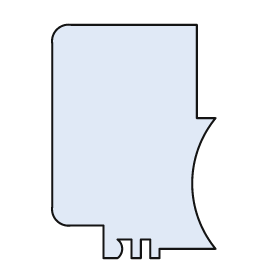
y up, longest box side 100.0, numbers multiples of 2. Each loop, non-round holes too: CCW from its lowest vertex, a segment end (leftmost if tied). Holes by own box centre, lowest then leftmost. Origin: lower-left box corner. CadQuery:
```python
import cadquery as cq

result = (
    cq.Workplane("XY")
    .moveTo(22.0, 0.0)
    .lineTo(28.0, 0.0)
    .threePointArc((30.0, 4.0), (28.0, 8.0))
    .lineTo(34.0, 8.0)
    .lineTo(34.0, 0.0)
    .lineTo(38.0, 0.0)
    .lineTo(38.0, 8.0)
    .lineTo(42.0, 8.0)
    .lineTo(42.0, 0.0)
    .lineTo(46.0, 0.0)
    .lineTo(46.0, 4.0)
    .lineTo(70.0, 4.0)
    .threePointArc((60.0, 32.0), (70.0, 60.0))
    .lineTo(62.0, 60.0)
    .lineTo(62.0, 100.0)
    .lineTo(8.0, 100.0)
    .threePointArc((2.0, 98.0), (0.0, 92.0))
    .lineTo(0.0, 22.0)
    .threePointArc((2.0, 16.0), (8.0, 14.0))
    .lineTo(22.0, 14.0)
    .close()
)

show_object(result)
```